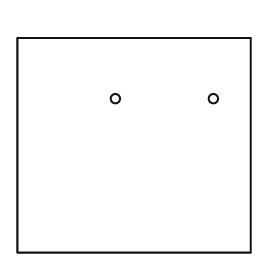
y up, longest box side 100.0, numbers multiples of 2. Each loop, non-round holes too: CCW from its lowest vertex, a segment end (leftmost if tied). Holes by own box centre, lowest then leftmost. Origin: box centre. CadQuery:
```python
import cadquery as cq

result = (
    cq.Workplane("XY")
    .moveTo(-50.0, -46.0)
    .lineTo(50.0, -46.0)
    .lineTo(50.0, 46.0)
    .lineTo(-50.0, 46.0)
    .close()
    .moveTo(-8.0, 20.0)
    .circle(2.0)
    .moveTo(34.0, 20.0)
    .circle(2.0)
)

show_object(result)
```